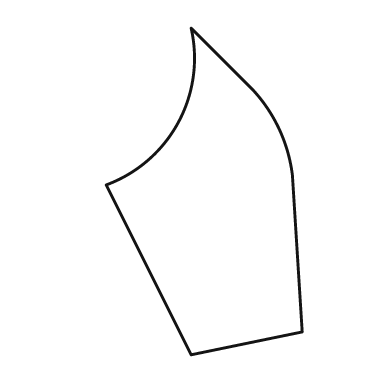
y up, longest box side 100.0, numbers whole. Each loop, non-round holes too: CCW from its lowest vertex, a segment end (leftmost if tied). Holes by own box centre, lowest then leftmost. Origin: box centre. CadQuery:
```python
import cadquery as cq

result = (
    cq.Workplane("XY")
    .moveTo(-4.0, -50.0)
    .lineTo(30.0, -43.0)
    .lineTo(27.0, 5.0)
    .threePointArc((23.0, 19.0), (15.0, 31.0))
    .lineTo(-4.0, 50.0)
    .threePointArc((-8.0, 21.0), (-30.0, 2.0))
    .close()
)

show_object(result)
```